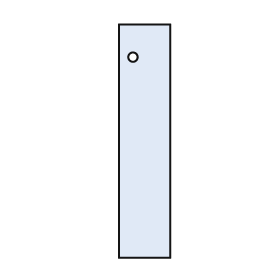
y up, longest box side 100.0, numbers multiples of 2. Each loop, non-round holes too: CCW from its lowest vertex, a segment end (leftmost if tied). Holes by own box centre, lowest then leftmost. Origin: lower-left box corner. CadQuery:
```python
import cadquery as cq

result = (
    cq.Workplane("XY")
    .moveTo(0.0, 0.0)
    .lineTo(22.0, 0.0)
    .lineTo(22.0, 100.0)
    .lineTo(0.0, 100.0)
    .close()
    .moveTo(6.0, 86.0)
    .circle(2.0)
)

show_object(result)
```